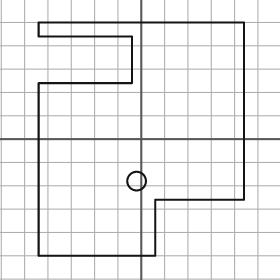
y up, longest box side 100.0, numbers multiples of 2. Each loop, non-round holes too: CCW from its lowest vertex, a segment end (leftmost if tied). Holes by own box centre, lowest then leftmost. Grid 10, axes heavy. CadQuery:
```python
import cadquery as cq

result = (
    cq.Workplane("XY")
    .moveTo(-44.0, -50.0)
    .lineTo(6.0, -50.0)
    .lineTo(6.0, -26.0)
    .lineTo(44.0, -26.0)
    .lineTo(44.0, 50.0)
    .lineTo(-44.0, 50.0)
    .lineTo(-44.0, 44.0)
    .lineTo(-4.0, 44.0)
    .lineTo(-4.0, 24.0)
    .lineTo(-44.0, 24.0)
    .close()
    .moveTo(-2.0, -18.0)
    .circle(4.0)
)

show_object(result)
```